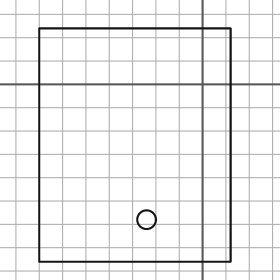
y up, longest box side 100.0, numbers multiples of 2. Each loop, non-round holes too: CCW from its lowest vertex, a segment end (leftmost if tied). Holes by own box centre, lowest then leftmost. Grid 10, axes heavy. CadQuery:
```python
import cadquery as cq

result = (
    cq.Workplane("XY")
    .moveTo(-70.0, -76.0)
    .lineTo(12.0, -76.0)
    .lineTo(12.0, 24.0)
    .lineTo(-70.0, 24.0)
    .close()
    .moveTo(-24.0, -58.0)
    .circle(4.0)
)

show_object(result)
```